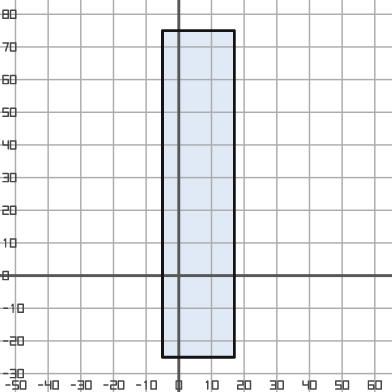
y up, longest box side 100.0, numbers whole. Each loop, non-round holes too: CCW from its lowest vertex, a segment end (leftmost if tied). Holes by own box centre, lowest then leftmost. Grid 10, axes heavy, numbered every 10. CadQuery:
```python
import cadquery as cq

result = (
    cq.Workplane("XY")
    .moveTo(-5.0, -25.0)
    .lineTo(17.0, -25.0)
    .lineTo(17.0, 75.0)
    .lineTo(-5.0, 75.0)
    .close()
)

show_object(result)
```